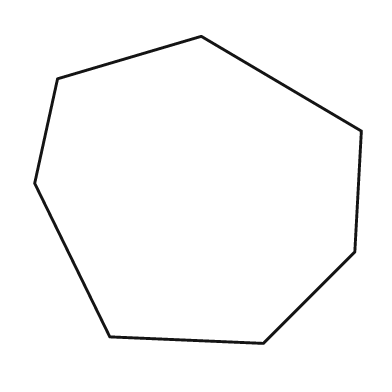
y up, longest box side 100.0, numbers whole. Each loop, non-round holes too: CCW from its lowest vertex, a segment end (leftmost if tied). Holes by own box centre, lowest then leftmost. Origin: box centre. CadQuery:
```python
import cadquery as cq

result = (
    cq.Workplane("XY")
    .moveTo(20.0, -47.0)
    .lineTo(48.0, -19.0)
    .lineTo(50.0, 18.0)
    .lineTo(1.0, 47.0)
    .lineTo(-43.0, 34.0)
    .lineTo(-50.0, 2.0)
    .lineTo(-27.0, -45.0)
    .close()
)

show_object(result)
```